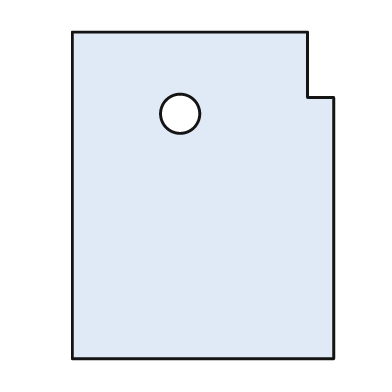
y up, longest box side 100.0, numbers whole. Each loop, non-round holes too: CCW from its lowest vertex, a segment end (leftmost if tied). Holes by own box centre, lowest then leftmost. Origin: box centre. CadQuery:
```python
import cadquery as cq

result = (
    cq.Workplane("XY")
    .moveTo(-40.0, -50.0)
    .lineTo(40.0, -50.0)
    .lineTo(40.0, 30.0)
    .lineTo(32.0, 30.0)
    .lineTo(32.0, 50.0)
    .lineTo(-40.0, 50.0)
    .close()
    .moveTo(-7.0, 25.0)
    .circle(6.0)
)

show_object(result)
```